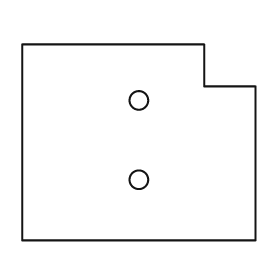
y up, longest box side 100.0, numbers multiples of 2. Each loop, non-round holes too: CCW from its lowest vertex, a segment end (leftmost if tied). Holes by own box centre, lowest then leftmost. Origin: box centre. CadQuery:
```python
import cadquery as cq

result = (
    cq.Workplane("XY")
    .moveTo(-50.0, -42.0)
    .lineTo(50.0, -42.0)
    .lineTo(50.0, 24.0)
    .lineTo(28.0, 24.0)
    .lineTo(28.0, 42.0)
    .lineTo(-50.0, 42.0)
    .close()
    .moveTo(0.0, -16.0)
    .circle(4.0)
    .moveTo(0.0, 18.0)
    .circle(4.0)
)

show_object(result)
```